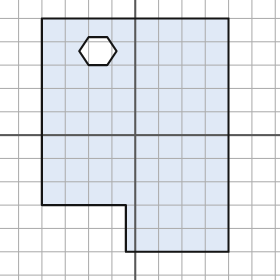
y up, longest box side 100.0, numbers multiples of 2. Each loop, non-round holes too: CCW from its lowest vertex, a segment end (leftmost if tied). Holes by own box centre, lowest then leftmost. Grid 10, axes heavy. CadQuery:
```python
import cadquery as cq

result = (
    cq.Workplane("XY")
    .moveTo(-4.0, -50.0)
    .lineTo(40.0, -50.0)
    .lineTo(40.0, 50.0)
    .lineTo(-40.0, 50.0)
    .lineTo(-40.0, -30.0)
    .lineTo(-4.0, -30.0)
    .close()
    .moveTo(-20.0, 30.0)
    .lineTo(-12.0, 30.0)
    .lineTo(-8.0, 36.0)
    .lineTo(-12.0, 42.0)
    .lineTo(-20.0, 42.0)
    .lineTo(-24.0, 36.0)
    .close()
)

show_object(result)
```